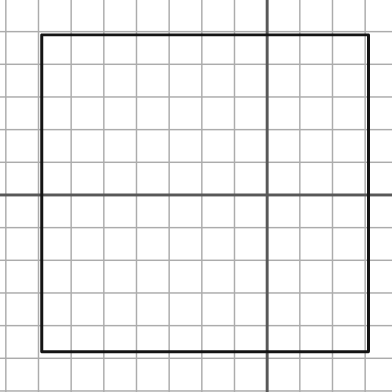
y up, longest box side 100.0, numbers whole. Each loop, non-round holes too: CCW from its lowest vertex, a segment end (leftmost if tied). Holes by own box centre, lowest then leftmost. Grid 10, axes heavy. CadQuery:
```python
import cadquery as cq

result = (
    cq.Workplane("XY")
    .moveTo(-69.0, -48.0)
    .lineTo(31.0, -48.0)
    .lineTo(31.0, 49.0)
    .lineTo(-69.0, 49.0)
    .close()
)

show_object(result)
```